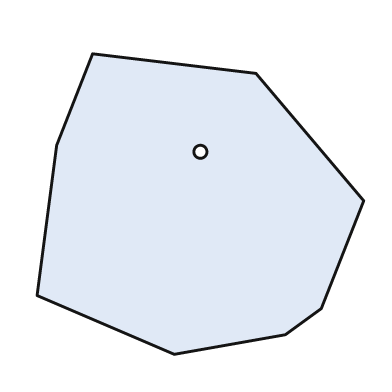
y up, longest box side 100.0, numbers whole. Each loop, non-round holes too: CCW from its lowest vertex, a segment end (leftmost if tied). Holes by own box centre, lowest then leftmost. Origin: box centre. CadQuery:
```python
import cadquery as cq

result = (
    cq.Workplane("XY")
    .moveTo(-8.0, -46.0)
    .lineTo(26.0, -40.0)
    .lineTo(37.0, -32.0)
    .lineTo(50.0, 1.0)
    .lineTo(17.0, 40.0)
    .lineTo(-33.0, 46.0)
    .lineTo(-44.0, 18.0)
    .lineTo(-50.0, -28.0)
    .close()
    .moveTo(0.0, 16.0)
    .circle(2.0)
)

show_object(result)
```